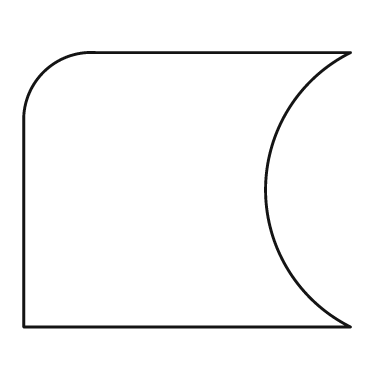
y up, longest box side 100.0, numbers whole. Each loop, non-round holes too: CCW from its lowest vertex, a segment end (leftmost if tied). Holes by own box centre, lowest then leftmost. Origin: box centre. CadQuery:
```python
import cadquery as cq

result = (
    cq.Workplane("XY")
    .moveTo(-50.0, -42.0)
    .lineTo(50.0, -42.0)
    .threePointArc((24.0, 0.0), (50.0, 42.0))
    .lineTo(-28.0, 42.0)
    .threePointArc((-44.0, 36.0), (-50.0, 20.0))
    .close()
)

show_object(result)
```